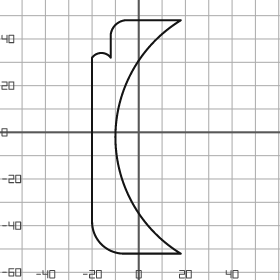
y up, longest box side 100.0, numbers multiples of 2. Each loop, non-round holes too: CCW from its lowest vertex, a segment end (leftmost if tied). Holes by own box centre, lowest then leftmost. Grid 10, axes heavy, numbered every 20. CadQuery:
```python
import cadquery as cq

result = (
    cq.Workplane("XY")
    .moveTo(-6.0, -52.0)
    .lineTo(18.0, -52.0)
    .threePointArc((-10.0, -2.0), (18.0, 48.0))
    .lineTo(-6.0, 48.0)
    .threePointArc((-10.0, 46.0), (-12.0, 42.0))
    .lineTo(-12.0, 32.0)
    .threePointArc((-16.0, 34.0), (-20.0, 32.0))
    .lineTo(-20.0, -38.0)
    .threePointArc((-16.0, -48.0), (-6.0, -52.0))
    .close()
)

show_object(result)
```